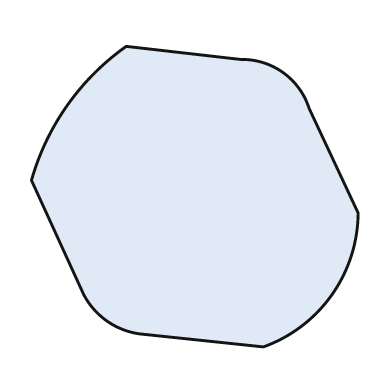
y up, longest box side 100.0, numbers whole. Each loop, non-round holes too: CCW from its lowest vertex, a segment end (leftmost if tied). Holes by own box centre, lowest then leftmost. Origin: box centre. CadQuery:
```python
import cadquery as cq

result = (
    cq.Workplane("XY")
    .moveTo(21.0, -46.0)
    .threePointArc((42.0, -30.0), (50.0, -5.0))
    .lineTo(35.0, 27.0)
    .threePointArc((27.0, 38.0), (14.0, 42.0))
    .lineTo(-21.0, 46.0)
    .threePointArc((-39.0, 28.0), (-50.0, 5.0))
    .lineTo(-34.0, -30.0)
    .threePointArc((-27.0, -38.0), (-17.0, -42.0))
    .close()
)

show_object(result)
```